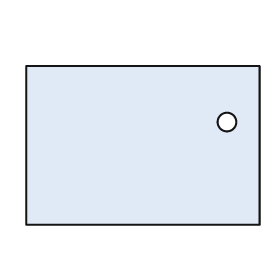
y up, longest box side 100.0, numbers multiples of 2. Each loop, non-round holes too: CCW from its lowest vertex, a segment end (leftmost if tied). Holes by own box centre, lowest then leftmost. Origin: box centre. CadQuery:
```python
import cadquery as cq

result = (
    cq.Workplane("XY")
    .moveTo(-50.0, -34.0)
    .lineTo(50.0, -34.0)
    .lineTo(50.0, 34.0)
    .lineTo(-50.0, 34.0)
    .close()
    .moveTo(36.0, 10.0)
    .circle(4.0)
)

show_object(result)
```